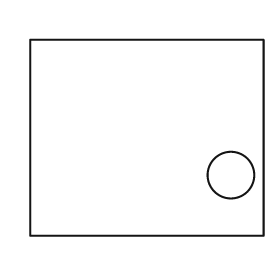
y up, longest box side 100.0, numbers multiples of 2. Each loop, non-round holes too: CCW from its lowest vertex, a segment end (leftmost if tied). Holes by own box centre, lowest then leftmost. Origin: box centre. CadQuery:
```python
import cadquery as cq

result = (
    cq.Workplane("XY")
    .moveTo(-50.0, -42.0)
    .lineTo(50.0, -42.0)
    .lineTo(50.0, 42.0)
    .lineTo(-50.0, 42.0)
    .close()
    .moveTo(36.0, -16.0)
    .circle(10.0)
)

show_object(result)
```